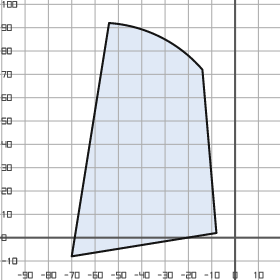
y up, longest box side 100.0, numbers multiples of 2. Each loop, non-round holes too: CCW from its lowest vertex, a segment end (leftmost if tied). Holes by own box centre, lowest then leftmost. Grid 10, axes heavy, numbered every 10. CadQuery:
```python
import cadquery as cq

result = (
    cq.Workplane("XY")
    .moveTo(-70.0, -8.0)
    .lineTo(-8.0, 2.0)
    .lineTo(-14.0, 72.0)
    .threePointArc((-32.0, 86.0), (-54.0, 92.0))
    .close()
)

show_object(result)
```